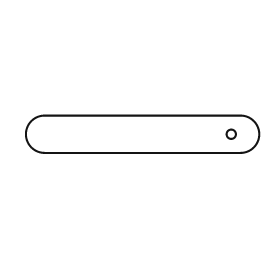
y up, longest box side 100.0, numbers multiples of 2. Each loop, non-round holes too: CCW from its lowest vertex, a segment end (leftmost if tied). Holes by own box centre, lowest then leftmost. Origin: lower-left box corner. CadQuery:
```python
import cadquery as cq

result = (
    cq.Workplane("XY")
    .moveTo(8.0, 0.0)
    .lineTo(92.0, 0.0)
    .threePointArc((100.0, 8.0), (92.0, 16.0))
    .lineTo(8.0, 16.0)
    .threePointArc((0.0, 8.0), (8.0, 0.0))
    .close()
    .moveTo(88.0, 8.0)
    .circle(2.0)
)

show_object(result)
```